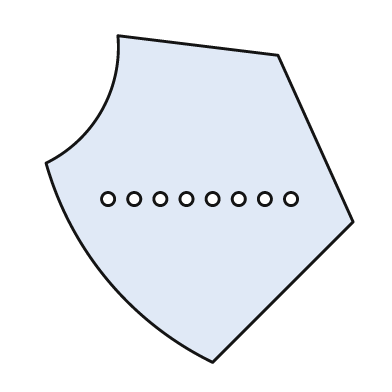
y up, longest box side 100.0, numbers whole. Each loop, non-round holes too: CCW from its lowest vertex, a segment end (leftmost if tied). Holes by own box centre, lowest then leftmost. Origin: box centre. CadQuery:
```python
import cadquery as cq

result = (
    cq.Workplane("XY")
    .moveTo(4.0, -50.0)
    .lineTo(47.0, -7.0)
    .lineTo(24.0, 44.0)
    .lineTo(-25.0, 50.0)
    .threePointArc((-30.0, 27.0), (-47.0, 11.0))
    .threePointArc((-28.0, -25.0), (4.0, -50.0))
    .close()
    .moveTo(-28.0, 0.0)
    .circle(2.0)
    .moveTo(-20.0, 0.0)
    .circle(2.0)
    .moveTo(-12.0, 0.0)
    .circle(2.0)
    .moveTo(-4.0, 0.0)
    .circle(2.0)
    .moveTo(4.0, 0.0)
    .circle(2.0)
    .moveTo(12.0, 0.0)
    .circle(2.0)
    .moveTo(20.0, 0.0)
    .circle(2.0)
    .moveTo(28.0, 0.0)
    .circle(2.0)
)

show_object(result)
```